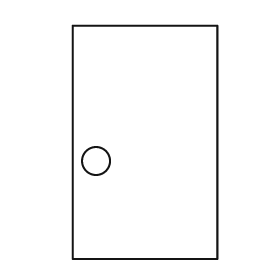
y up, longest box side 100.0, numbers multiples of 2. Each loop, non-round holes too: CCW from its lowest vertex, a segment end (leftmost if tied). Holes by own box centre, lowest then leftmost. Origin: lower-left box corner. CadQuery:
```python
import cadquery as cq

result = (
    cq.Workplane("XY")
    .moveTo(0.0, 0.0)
    .lineTo(62.0, 0.0)
    .lineTo(62.0, 100.0)
    .lineTo(0.0, 100.0)
    .close()
    .moveTo(10.0, 42.0)
    .circle(6.0)
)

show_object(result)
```